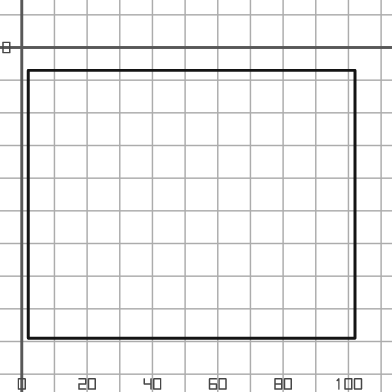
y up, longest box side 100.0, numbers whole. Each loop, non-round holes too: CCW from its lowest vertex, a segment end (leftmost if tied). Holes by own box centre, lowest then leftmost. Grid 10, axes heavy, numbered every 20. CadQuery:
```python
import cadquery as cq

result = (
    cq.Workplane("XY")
    .moveTo(2.0, -89.0)
    .lineTo(102.0, -89.0)
    .lineTo(102.0, -7.0)
    .lineTo(2.0, -7.0)
    .close()
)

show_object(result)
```